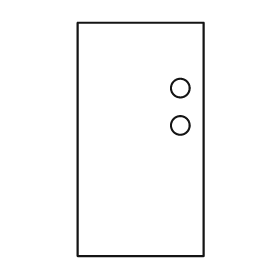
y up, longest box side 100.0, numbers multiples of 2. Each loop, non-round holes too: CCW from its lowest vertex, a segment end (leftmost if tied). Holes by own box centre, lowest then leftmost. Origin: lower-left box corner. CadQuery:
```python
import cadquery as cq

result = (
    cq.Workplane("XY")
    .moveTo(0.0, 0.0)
    .lineTo(54.0, 0.0)
    .lineTo(54.0, 100.0)
    .lineTo(0.0, 100.0)
    .close()
    .moveTo(44.0, 56.0)
    .circle(4.0)
    .moveTo(44.0, 72.0)
    .circle(4.0)
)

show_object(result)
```